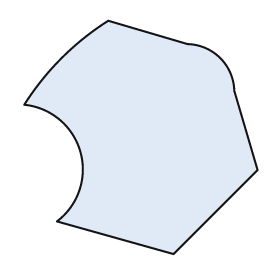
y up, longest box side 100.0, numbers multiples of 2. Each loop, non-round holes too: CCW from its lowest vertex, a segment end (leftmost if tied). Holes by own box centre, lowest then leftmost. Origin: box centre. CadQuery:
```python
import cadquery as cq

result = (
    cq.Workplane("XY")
    .moveTo(14.0, -50.0)
    .lineTo(50.0, -14.0)
    .lineTo(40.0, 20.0)
    .threePointArc((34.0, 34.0), (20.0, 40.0))
    .lineTo(-14.0, 50.0)
    .threePointArc((-34.0, 34.0), (-50.0, 14.0))
    .threePointArc((-26.0, -6.0), (-36.0, -36.0))
    .close()
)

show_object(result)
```